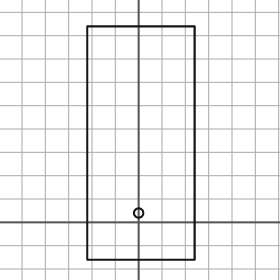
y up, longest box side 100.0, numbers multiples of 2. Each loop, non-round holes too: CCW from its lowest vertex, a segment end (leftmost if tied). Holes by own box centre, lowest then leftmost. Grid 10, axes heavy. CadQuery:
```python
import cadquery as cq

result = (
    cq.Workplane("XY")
    .moveTo(-22.0, -16.0)
    .lineTo(24.0, -16.0)
    .lineTo(24.0, 84.0)
    .lineTo(-22.0, 84.0)
    .close()
    .moveTo(0.0, 4.0)
    .circle(2.0)
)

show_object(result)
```